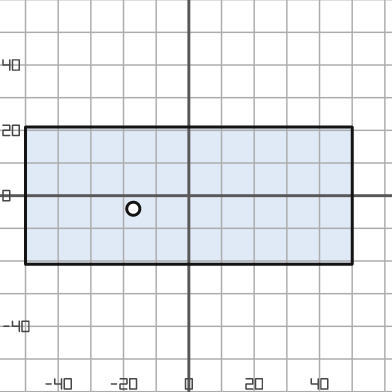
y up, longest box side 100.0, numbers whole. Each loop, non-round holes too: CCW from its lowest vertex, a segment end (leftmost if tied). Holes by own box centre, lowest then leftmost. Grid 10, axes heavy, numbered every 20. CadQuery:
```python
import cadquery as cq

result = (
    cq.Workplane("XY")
    .moveTo(-50.0, -21.0)
    .lineTo(50.0, -21.0)
    .lineTo(50.0, 21.0)
    .lineTo(-50.0, 21.0)
    .close()
    .moveTo(-17.0, -4.0)
    .circle(2.0)
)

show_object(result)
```